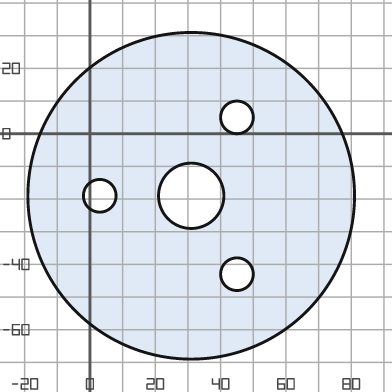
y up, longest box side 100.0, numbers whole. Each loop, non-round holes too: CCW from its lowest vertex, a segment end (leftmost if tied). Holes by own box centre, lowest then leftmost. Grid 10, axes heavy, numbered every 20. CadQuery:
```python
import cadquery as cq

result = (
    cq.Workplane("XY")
    .moveTo(31.0, -19.0)
    .circle(50.0)
    .moveTo(45.0, -43.0)
    .circle(5.0)
    .moveTo(3.0, -19.0)
    .circle(5.0)
    .moveTo(31.0, -19.0)
    .circle(10.0)
    .moveTo(45.0, 5.0)
    .circle(5.0)
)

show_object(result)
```